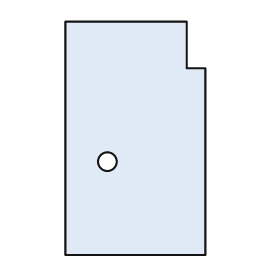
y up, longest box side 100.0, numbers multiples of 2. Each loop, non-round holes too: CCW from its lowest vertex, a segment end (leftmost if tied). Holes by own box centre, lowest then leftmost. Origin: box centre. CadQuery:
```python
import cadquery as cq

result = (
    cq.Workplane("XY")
    .moveTo(-30.0, -50.0)
    .lineTo(30.0, -50.0)
    .lineTo(30.0, 30.0)
    .lineTo(22.0, 30.0)
    .lineTo(22.0, 50.0)
    .lineTo(-30.0, 50.0)
    .close()
    .moveTo(-12.0, -10.0)
    .circle(4.0)
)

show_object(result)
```